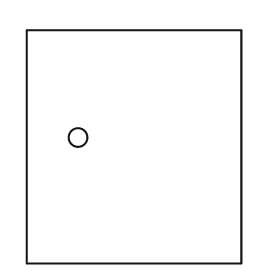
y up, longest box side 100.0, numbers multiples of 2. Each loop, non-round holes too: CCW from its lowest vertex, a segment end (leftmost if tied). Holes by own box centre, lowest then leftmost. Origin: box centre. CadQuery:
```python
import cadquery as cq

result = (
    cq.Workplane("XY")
    .moveTo(-46.0, -50.0)
    .lineTo(46.0, -50.0)
    .lineTo(46.0, 50.0)
    .lineTo(-46.0, 50.0)
    .close()
    .moveTo(-24.0, 4.0)
    .circle(4.0)
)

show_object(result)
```